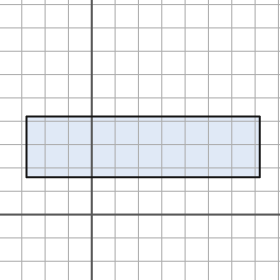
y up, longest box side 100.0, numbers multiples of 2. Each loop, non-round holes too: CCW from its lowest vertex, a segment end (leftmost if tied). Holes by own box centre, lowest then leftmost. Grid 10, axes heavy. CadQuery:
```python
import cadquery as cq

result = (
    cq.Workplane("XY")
    .moveTo(-28.0, 16.0)
    .lineTo(72.0, 16.0)
    .lineTo(72.0, 42.0)
    .lineTo(-28.0, 42.0)
    .close()
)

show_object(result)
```